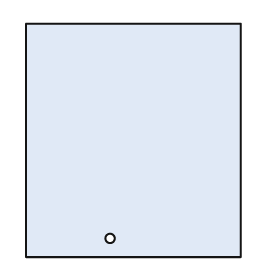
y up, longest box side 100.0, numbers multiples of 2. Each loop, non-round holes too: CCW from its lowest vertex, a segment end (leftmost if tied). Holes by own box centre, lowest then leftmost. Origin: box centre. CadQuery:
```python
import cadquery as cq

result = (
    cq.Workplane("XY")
    .moveTo(-46.0, -50.0)
    .lineTo(46.0, -50.0)
    .lineTo(46.0, 50.0)
    .lineTo(-46.0, 50.0)
    .close()
    .moveTo(-10.0, -42.0)
    .circle(2.0)
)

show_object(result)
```